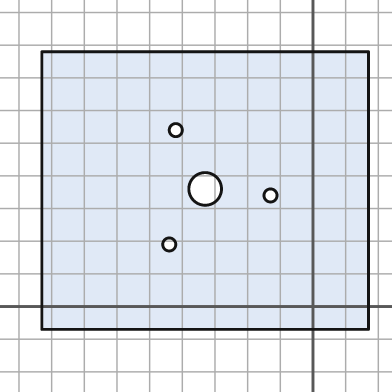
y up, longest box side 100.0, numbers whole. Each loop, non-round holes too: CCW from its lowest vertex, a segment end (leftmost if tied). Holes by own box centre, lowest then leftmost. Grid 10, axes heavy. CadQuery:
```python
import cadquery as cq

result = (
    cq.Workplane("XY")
    .moveTo(-83.0, -7.0)
    .lineTo(17.0, -7.0)
    .lineTo(17.0, 78.0)
    .lineTo(-83.0, 78.0)
    .close()
    .moveTo(-44.0, 19.0)
    .circle(2.0)
    .moveTo(-13.0, 34.0)
    .circle(2.0)
    .moveTo(-33.0, 36.0)
    .circle(5.0)
    .moveTo(-42.0, 54.0)
    .circle(2.0)
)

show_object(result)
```